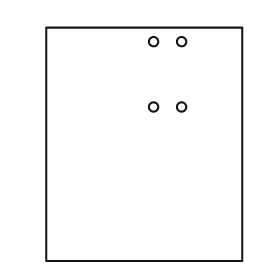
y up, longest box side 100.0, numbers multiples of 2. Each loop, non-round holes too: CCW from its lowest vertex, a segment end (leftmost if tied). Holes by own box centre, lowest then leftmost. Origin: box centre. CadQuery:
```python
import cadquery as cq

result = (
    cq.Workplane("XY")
    .moveTo(-42.0, -50.0)
    .lineTo(42.0, -50.0)
    .lineTo(42.0, 50.0)
    .lineTo(-42.0, 50.0)
    .close()
    .moveTo(4.0, 16.0)
    .circle(2.0)
    .moveTo(16.0, 16.0)
    .circle(2.0)
    .moveTo(4.0, 44.0)
    .circle(2.0)
    .moveTo(16.0, 44.0)
    .circle(2.0)
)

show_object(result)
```